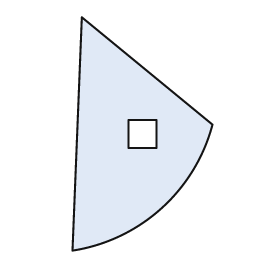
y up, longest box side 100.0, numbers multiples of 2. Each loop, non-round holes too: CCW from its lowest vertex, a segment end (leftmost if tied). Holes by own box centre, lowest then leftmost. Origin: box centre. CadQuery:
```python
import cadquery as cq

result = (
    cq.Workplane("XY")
    .moveTo(-30.0, -50.0)
    .threePointArc((8.0, -32.0), (30.0, 4.0))
    .lineTo(-26.0, 50.0)
    .close()
    .moveTo(-6.0, -6.0)
    .lineTo(6.0, -6.0)
    .lineTo(6.0, 6.0)
    .lineTo(-6.0, 6.0)
    .close()
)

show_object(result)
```